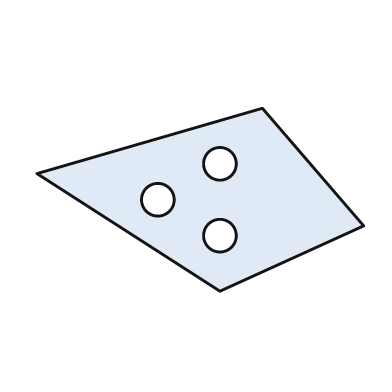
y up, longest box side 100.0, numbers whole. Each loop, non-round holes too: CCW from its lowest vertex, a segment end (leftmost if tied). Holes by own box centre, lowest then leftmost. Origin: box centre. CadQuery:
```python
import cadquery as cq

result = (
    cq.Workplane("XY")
    .moveTo(6.0, -28.0)
    .lineTo(50.0, -8.0)
    .lineTo(19.0, 28.0)
    .lineTo(-50.0, 8.0)
    .close()
    .moveTo(6.0, -11.0)
    .circle(5.0)
    .moveTo(-13.0, 0.0)
    .circle(5.0)
    .moveTo(6.0, 11.0)
    .circle(5.0)
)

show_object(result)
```